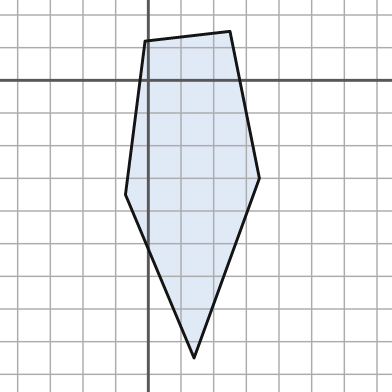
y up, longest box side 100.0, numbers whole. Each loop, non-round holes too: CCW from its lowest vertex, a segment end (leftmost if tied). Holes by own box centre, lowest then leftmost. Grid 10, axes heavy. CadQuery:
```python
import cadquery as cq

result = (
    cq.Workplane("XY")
    .moveTo(14.0, -85.0)
    .lineTo(34.0, -30.0)
    .lineTo(25.0, 15.0)
    .lineTo(-1.0, 12.0)
    .lineTo(-7.0, -35.0)
    .close()
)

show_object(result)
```